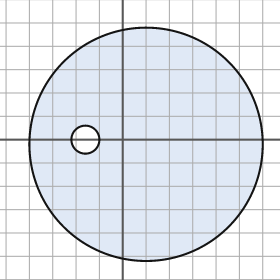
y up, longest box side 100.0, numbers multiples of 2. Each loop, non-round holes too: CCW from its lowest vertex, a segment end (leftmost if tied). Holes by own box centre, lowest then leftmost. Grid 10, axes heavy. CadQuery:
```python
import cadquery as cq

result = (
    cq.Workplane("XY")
    .moveTo(10.0, -2.0)
    .circle(50.0)
    .moveTo(-16.0, 0.0)
    .circle(6.0)
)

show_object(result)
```